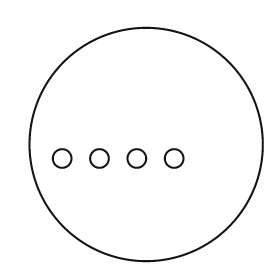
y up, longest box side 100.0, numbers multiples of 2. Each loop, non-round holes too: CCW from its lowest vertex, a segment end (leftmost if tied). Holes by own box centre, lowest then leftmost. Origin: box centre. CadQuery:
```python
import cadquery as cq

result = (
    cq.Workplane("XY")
    .moveTo(0.0, 0.0)
    .circle(50.0)
    .moveTo(-36.0, -6.0)
    .circle(4.0)
    .moveTo(-20.0, -6.0)
    .circle(4.0)
    .moveTo(-4.0, -6.0)
    .circle(4.0)
    .moveTo(12.0, -6.0)
    .circle(4.0)
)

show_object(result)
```